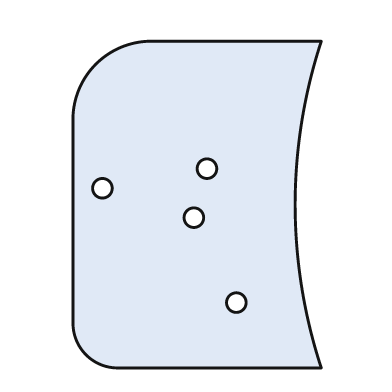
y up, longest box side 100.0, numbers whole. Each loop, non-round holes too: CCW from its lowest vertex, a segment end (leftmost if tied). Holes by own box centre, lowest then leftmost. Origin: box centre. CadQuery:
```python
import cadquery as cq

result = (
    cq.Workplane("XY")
    .moveTo(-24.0, -50.0)
    .lineTo(38.0, -50.0)
    .threePointArc((30.0, 0.0), (38.0, 50.0))
    .lineTo(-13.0, 50.0)
    .threePointArc((-31.0, 43.0), (-38.0, 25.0))
    .lineTo(-38.0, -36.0)
    .threePointArc((-34.0, -46.0), (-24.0, -50.0))
    .close()
    .moveTo(12.0, -30.0)
    .circle(3.0)
    .moveTo(-1.0, -4.0)
    .circle(3.0)
    .moveTo(-29.0, 5.0)
    .circle(3.0)
    .moveTo(3.0, 11.0)
    .circle(3.0)
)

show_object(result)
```